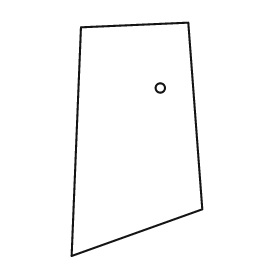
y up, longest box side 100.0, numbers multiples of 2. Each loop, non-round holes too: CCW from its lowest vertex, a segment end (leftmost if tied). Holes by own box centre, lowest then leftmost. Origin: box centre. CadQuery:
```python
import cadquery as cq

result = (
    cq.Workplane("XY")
    .moveTo(-28.0, -50.0)
    .lineTo(28.0, -30.0)
    .lineTo(22.0, 50.0)
    .lineTo(-24.0, 48.0)
    .close()
    .moveTo(10.0, 22.0)
    .circle(2.0)
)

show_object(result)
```